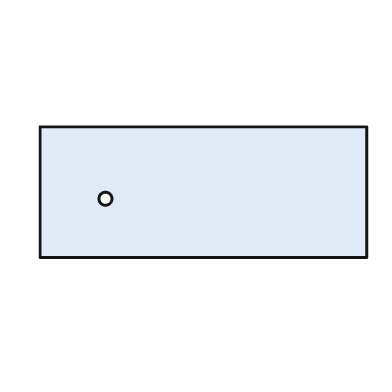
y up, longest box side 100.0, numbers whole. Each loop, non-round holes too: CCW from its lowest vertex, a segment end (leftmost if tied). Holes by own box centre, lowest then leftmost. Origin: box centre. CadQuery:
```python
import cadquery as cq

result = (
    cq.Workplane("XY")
    .moveTo(-50.0, -20.0)
    .lineTo(50.0, -20.0)
    .lineTo(50.0, 20.0)
    .lineTo(-50.0, 20.0)
    .close()
    .moveTo(-30.0, -2.0)
    .circle(2.0)
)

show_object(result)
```